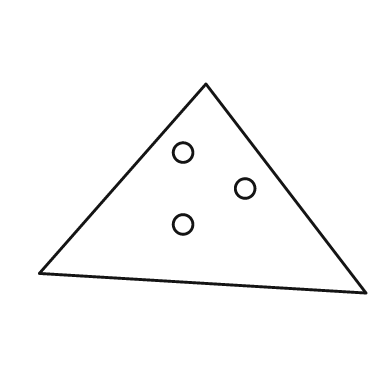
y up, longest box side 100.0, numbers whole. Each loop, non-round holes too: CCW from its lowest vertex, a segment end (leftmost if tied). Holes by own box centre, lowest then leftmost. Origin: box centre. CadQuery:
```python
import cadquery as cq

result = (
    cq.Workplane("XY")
    .moveTo(50.0, -32.0)
    .lineTo(1.0, 32.0)
    .lineTo(-50.0, -26.0)
    .close()
    .moveTo(-6.0, -11.0)
    .circle(3.0)
    .moveTo(13.0, 0.0)
    .circle(3.0)
    .moveTo(-6.0, 11.0)
    .circle(3.0)
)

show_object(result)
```